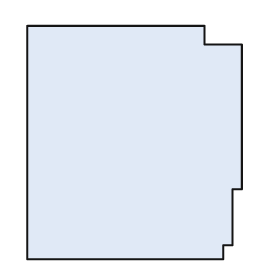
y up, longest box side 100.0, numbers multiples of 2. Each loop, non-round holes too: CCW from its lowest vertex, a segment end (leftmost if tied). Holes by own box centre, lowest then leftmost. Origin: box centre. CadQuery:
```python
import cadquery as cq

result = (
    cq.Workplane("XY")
    .moveTo(-46.0, -50.0)
    .lineTo(38.0, -50.0)
    .lineTo(38.0, -44.0)
    .lineTo(42.0, -44.0)
    .lineTo(42.0, -20.0)
    .lineTo(46.0, -20.0)
    .lineTo(46.0, 42.0)
    .lineTo(30.0, 42.0)
    .lineTo(30.0, 50.0)
    .lineTo(-46.0, 50.0)
    .close()
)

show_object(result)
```